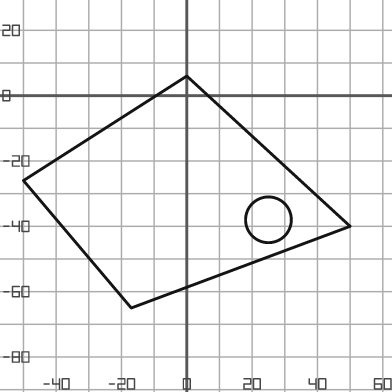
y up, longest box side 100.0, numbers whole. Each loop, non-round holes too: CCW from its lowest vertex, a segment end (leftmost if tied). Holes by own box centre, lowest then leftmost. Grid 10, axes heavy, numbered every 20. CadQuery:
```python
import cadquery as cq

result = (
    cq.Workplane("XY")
    .moveTo(-17.0, -65.0)
    .lineTo(50.0, -40.0)
    .lineTo(0.0, 6.0)
    .lineTo(-50.0, -26.0)
    .close()
    .moveTo(25.0, -38.0)
    .circle(7.0)
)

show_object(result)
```